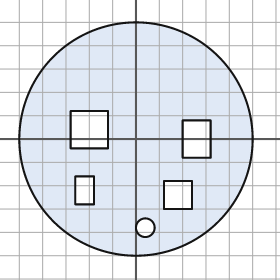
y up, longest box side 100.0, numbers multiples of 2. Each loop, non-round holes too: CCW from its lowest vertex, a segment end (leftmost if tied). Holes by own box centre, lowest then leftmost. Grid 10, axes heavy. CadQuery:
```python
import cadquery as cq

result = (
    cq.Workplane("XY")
    .moveTo(0.0, 0.0)
    .circle(50.0)
    .moveTo(4.0, -38.0)
    .circle(4.0)
    .moveTo(12.0, -30.0)
    .lineTo(24.0, -30.0)
    .lineTo(24.0, -18.0)
    .lineTo(12.0, -18.0)
    .close()
    .moveTo(-26.0, -28.0)
    .lineTo(-18.0, -28.0)
    .lineTo(-18.0, -16.0)
    .lineTo(-26.0, -16.0)
    .close()
    .moveTo(20.0, -8.0)
    .lineTo(32.0, -8.0)
    .lineTo(32.0, 8.0)
    .lineTo(20.0, 8.0)
    .close()
    .moveTo(-28.0, -4.0)
    .lineTo(-12.0, -4.0)
    .lineTo(-12.0, 12.0)
    .lineTo(-28.0, 12.0)
    .close()
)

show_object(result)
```